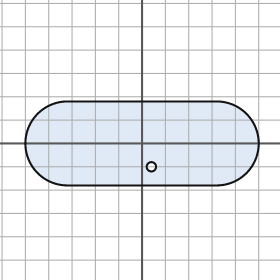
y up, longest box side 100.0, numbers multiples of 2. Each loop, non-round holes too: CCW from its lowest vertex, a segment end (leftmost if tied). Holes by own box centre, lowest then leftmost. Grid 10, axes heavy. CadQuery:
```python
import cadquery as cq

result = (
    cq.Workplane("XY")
    .moveTo(-32.0, -18.0)
    .lineTo(32.0, -18.0)
    .threePointArc((50.0, 0.0), (32.0, 18.0))
    .lineTo(-32.0, 18.0)
    .threePointArc((-50.0, 0.0), (-32.0, -18.0))
    .close()
    .moveTo(4.0, -10.0)
    .circle(2.0)
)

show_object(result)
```